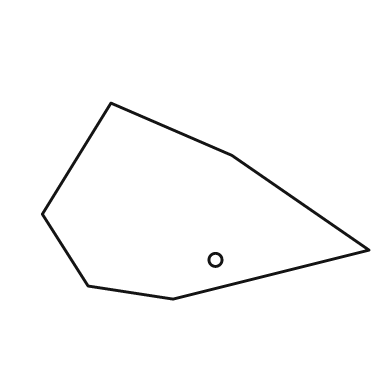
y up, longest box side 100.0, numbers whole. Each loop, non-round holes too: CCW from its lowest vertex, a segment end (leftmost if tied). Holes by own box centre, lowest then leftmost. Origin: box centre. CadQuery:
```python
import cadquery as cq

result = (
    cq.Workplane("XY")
    .moveTo(-10.0, -30.0)
    .lineTo(50.0, -15.0)
    .lineTo(8.0, 14.0)
    .lineTo(-29.0, 30.0)
    .lineTo(-50.0, -4.0)
    .lineTo(-36.0, -26.0)
    .close()
    .moveTo(3.0, -18.0)
    .circle(2.0)
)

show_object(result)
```